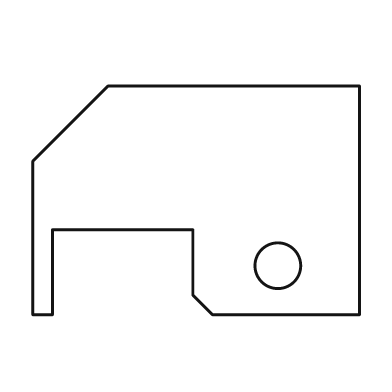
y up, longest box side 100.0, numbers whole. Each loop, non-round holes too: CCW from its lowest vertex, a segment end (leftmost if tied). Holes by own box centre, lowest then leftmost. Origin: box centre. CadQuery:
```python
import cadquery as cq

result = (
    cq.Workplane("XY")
    .moveTo(-50.0, -35.0)
    .lineTo(-44.0, -35.0)
    .lineTo(-44.0, -9.0)
    .lineTo(-1.0, -9.0)
    .lineTo(-1.0, -29.0)
    .lineTo(5.0, -35.0)
    .lineTo(50.0, -35.0)
    .lineTo(50.0, 35.0)
    .lineTo(-27.0, 35.0)
    .lineTo(-50.0, 12.0)
    .close()
    .moveTo(25.0, -20.0)
    .circle(7.0)
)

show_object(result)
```